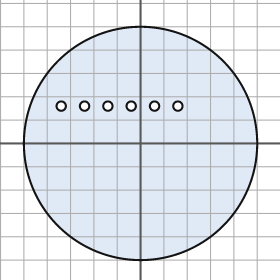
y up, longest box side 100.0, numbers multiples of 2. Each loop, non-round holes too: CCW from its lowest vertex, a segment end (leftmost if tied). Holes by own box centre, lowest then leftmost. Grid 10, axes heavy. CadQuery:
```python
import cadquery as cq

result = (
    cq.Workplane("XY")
    .moveTo(0.0, 0.0)
    .circle(50.0)
    .moveTo(-34.0, 16.0)
    .circle(2.0)
    .moveTo(-24.0, 16.0)
    .circle(2.0)
    .moveTo(-14.0, 16.0)
    .circle(2.0)
    .moveTo(-4.0, 16.0)
    .circle(2.0)
    .moveTo(6.0, 16.0)
    .circle(2.0)
    .moveTo(16.0, 16.0)
    .circle(2.0)
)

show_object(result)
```